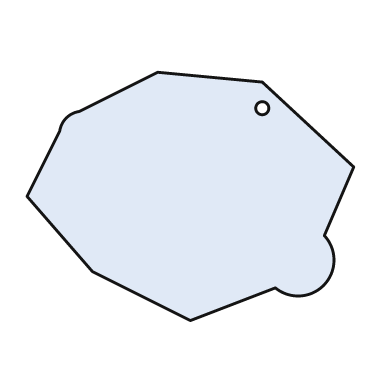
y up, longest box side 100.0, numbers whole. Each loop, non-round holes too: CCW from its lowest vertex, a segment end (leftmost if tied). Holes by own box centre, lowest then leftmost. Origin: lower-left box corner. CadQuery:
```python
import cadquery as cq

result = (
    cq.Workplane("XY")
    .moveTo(50.0, 0.0)
    .lineTo(76.0, 10.0)
    .threePointArc((91.0, 11.0), (91.0, 26.0))
    .lineTo(100.0, 47.0)
    .lineTo(72.0, 73.0)
    .lineTo(40.0, 76.0)
    .lineTo(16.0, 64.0)
    .threePointArc((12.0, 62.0), (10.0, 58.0))
    .lineTo(0.0, 38.0)
    .lineTo(20.0, 15.0)
    .close()
    .moveTo(72.0, 65.0)
    .circle(2.0)
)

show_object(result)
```